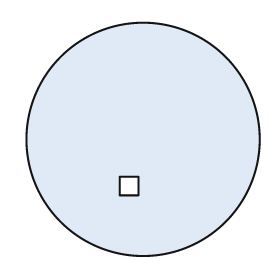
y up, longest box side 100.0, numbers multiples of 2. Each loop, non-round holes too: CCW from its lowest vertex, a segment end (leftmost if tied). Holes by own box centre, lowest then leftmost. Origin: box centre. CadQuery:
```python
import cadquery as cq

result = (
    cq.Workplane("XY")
    .moveTo(0.0, 0.0)
    .circle(50.0)
    .moveTo(-10.0, -24.0)
    .lineTo(-2.0, -24.0)
    .lineTo(-2.0, -16.0)
    .lineTo(-10.0, -16.0)
    .close()
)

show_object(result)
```